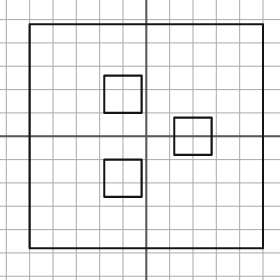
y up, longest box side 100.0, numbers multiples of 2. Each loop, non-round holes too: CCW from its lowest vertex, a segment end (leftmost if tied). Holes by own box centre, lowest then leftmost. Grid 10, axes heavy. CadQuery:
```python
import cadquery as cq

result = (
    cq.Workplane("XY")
    .moveTo(-50.0, -48.0)
    .lineTo(50.0, -48.0)
    .lineTo(50.0, 48.0)
    .lineTo(-50.0, 48.0)
    .close()
    .moveTo(-18.0, -26.0)
    .lineTo(-2.0, -26.0)
    .lineTo(-2.0, -10.0)
    .lineTo(-18.0, -10.0)
    .close()
    .moveTo(12.0, -8.0)
    .lineTo(28.0, -8.0)
    .lineTo(28.0, 8.0)
    .lineTo(12.0, 8.0)
    .close()
    .moveTo(-18.0, 10.0)
    .lineTo(-2.0, 10.0)
    .lineTo(-2.0, 26.0)
    .lineTo(-18.0, 26.0)
    .close()
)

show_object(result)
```